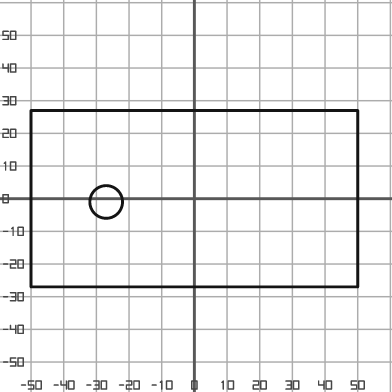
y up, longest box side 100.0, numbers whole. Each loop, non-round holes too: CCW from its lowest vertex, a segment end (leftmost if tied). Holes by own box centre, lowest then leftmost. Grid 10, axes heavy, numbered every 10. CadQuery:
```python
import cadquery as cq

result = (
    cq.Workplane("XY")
    .moveTo(-50.0, -27.0)
    .lineTo(50.0, -27.0)
    .lineTo(50.0, 27.0)
    .lineTo(-50.0, 27.0)
    .close()
    .moveTo(-27.0, -1.0)
    .circle(5.0)
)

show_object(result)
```